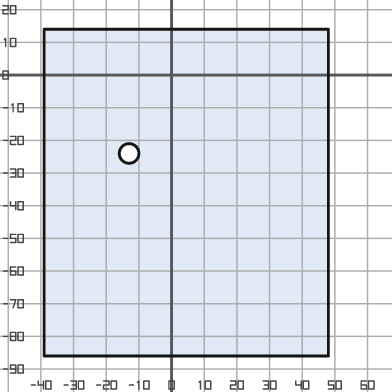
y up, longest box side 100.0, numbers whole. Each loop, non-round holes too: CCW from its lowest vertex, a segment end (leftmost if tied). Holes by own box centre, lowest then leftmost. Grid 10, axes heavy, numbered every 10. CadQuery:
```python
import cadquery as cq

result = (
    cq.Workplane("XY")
    .moveTo(-39.0, -86.0)
    .lineTo(48.0, -86.0)
    .lineTo(48.0, 14.0)
    .lineTo(-39.0, 14.0)
    .close()
    .moveTo(-13.0, -24.0)
    .circle(3.0)
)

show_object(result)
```